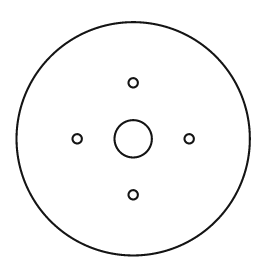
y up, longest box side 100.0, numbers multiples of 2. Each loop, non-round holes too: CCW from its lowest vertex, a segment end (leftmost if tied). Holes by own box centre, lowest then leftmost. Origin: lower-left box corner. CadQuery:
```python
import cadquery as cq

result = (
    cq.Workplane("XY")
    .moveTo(50.0, 50.0)
    .circle(50.0)
    .moveTo(50.0, 26.0)
    .circle(2.0)
    .moveTo(26.0, 50.0)
    .circle(2.0)
    .moveTo(50.0, 50.0)
    .circle(8.0)
    .moveTo(74.0, 50.0)
    .circle(2.0)
    .moveTo(50.0, 74.0)
    .circle(2.0)
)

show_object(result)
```